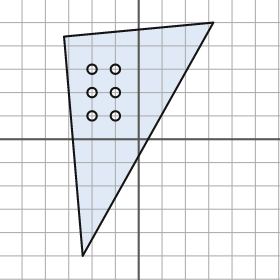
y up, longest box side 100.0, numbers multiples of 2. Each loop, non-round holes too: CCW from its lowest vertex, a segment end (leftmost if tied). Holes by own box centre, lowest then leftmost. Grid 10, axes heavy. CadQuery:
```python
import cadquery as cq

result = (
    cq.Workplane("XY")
    .moveTo(-24.0, -50.0)
    .lineTo(32.0, 50.0)
    .lineTo(-32.0, 44.0)
    .close()
    .moveTo(-20.0, 10.0)
    .circle(2.0)
    .moveTo(-10.0, 10.0)
    .circle(2.0)
    .moveTo(-20.0, 20.0)
    .circle(2.0)
    .moveTo(-10.0, 20.0)
    .circle(2.0)
    .moveTo(-20.0, 30.0)
    .circle(2.0)
    .moveTo(-10.0, 30.0)
    .circle(2.0)
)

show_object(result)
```